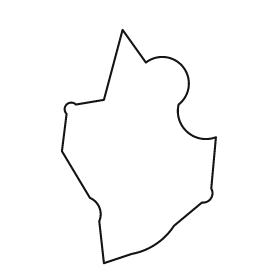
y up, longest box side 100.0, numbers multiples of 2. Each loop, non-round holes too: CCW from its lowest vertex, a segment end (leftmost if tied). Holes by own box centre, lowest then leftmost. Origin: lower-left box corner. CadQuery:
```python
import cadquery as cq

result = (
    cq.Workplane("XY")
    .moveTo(18.0, 0.0)
    .lineTo(30.0, 4.0)
    .threePointArc((40.0, 8.0), (48.0, 16.0))
    .lineTo(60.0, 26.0)
    .threePointArc((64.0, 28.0), (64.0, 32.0))
    .lineTo(66.0, 54.0)
    .threePointArc((54.0, 56.0), (50.0, 68.0))
    .threePointArc((52.0, 84.0), (36.0, 86.0))
    .lineTo(26.0, 100.0)
    .lineTo(18.0, 70.0)
    .lineTo(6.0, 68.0)
    .threePointArc((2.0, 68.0), (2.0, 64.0))
    .lineTo(0.0, 48.0)
    .lineTo(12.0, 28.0)
    .threePointArc((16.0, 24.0), (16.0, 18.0))
    .close()
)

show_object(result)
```